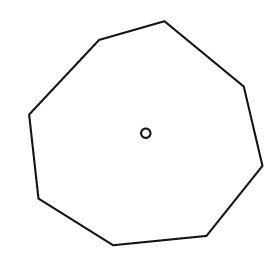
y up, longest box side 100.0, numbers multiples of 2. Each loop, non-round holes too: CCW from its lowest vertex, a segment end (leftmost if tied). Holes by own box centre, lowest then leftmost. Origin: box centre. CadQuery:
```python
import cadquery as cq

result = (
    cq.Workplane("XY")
    .moveTo(-14.0, -48.0)
    .lineTo(26.0, -44.0)
    .lineTo(50.0, -14.0)
    .lineTo(42.0, 20.0)
    .lineTo(8.0, 48.0)
    .lineTo(-20.0, 40.0)
    .lineTo(-50.0, 8.0)
    .lineTo(-46.0, -28.0)
    .close()
    .moveTo(0.0, 0.0)
    .circle(2.0)
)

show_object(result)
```